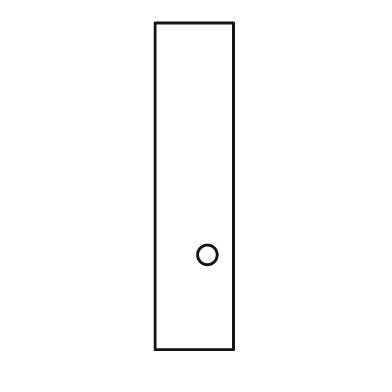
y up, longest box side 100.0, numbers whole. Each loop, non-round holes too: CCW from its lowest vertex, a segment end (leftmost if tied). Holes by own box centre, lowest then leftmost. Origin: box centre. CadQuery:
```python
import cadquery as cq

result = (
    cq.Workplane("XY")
    .moveTo(-12.0, -50.0)
    .lineTo(12.0, -50.0)
    .lineTo(12.0, 50.0)
    .lineTo(-12.0, 50.0)
    .close()
    .moveTo(4.0, -21.0)
    .circle(3.0)
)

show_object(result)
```